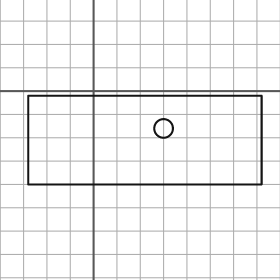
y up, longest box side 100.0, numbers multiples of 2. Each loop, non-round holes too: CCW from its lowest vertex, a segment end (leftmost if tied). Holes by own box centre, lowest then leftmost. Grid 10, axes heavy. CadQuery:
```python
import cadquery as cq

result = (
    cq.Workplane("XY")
    .moveTo(-28.0, -40.0)
    .lineTo(72.0, -40.0)
    .lineTo(72.0, -2.0)
    .lineTo(-28.0, -2.0)
    .close()
    .moveTo(30.0, -16.0)
    .circle(4.0)
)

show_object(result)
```